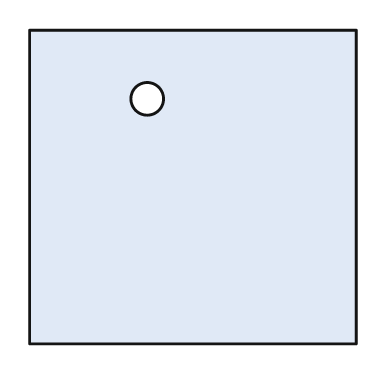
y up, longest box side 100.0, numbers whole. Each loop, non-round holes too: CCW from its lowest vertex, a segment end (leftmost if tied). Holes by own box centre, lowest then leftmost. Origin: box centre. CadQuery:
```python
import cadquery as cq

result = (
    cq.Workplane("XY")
    .moveTo(-50.0, -48.0)
    .lineTo(50.0, -48.0)
    .lineTo(50.0, 48.0)
    .lineTo(-50.0, 48.0)
    .close()
    .moveTo(-14.0, 27.0)
    .circle(5.0)
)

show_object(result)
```